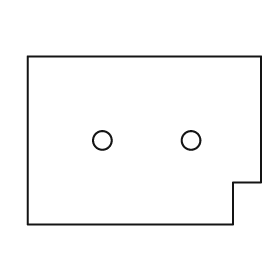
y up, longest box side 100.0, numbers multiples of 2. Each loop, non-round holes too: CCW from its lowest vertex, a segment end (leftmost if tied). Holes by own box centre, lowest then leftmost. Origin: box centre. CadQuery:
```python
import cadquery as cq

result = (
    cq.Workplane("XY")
    .moveTo(-50.0, -36.0)
    .lineTo(38.0, -36.0)
    .lineTo(38.0, -18.0)
    .lineTo(50.0, -18.0)
    .lineTo(50.0, 36.0)
    .lineTo(-50.0, 36.0)
    .close()
    .moveTo(-18.0, 0.0)
    .circle(4.0)
    .moveTo(20.0, 0.0)
    .circle(4.0)
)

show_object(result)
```